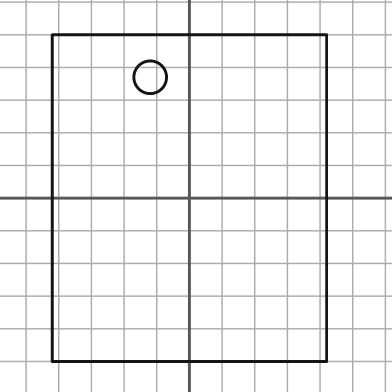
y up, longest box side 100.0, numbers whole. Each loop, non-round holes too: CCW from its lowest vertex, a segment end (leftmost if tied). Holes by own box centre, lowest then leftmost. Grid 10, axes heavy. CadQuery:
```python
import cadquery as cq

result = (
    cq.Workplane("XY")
    .moveTo(-42.0, -50.0)
    .lineTo(42.0, -50.0)
    .lineTo(42.0, 50.0)
    .lineTo(-42.0, 50.0)
    .close()
    .moveTo(-12.0, 37.0)
    .circle(5.0)
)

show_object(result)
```